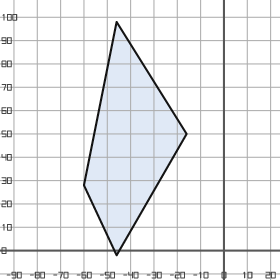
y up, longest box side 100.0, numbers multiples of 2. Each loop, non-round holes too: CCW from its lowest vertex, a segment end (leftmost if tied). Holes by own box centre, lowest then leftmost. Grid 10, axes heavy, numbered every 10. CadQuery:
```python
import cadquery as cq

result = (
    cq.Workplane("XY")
    .moveTo(-46.0, -2.0)
    .lineTo(-16.0, 50.0)
    .lineTo(-46.0, 98.0)
    .lineTo(-60.0, 28.0)
    .close()
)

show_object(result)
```